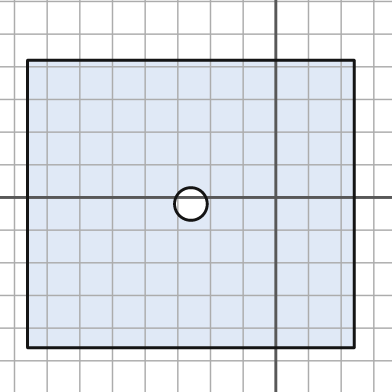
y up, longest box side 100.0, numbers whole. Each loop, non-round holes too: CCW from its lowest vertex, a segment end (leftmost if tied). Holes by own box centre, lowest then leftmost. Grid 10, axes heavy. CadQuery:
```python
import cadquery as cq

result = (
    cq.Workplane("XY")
    .moveTo(-76.0, -46.0)
    .lineTo(24.0, -46.0)
    .lineTo(24.0, 42.0)
    .lineTo(-76.0, 42.0)
    .close()
    .moveTo(-26.0, -2.0)
    .circle(5.0)
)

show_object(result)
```